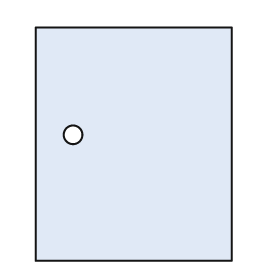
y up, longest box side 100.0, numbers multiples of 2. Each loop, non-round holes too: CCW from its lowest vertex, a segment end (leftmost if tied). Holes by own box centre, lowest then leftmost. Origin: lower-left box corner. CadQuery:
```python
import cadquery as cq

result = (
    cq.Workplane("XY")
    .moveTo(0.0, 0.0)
    .lineTo(84.0, 0.0)
    .lineTo(84.0, 100.0)
    .lineTo(0.0, 100.0)
    .close()
    .moveTo(16.0, 54.0)
    .circle(4.0)
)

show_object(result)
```